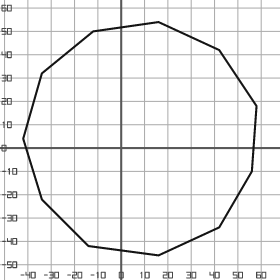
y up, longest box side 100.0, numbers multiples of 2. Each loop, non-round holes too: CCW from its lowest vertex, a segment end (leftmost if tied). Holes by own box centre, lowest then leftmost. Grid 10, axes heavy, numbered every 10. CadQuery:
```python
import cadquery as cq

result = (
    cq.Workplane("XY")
    .moveTo(16.0, -46.0)
    .lineTo(42.0, -34.0)
    .lineTo(56.0, -10.0)
    .lineTo(58.0, 18.0)
    .lineTo(42.0, 42.0)
    .lineTo(16.0, 54.0)
    .lineTo(-12.0, 50.0)
    .lineTo(-34.0, 32.0)
    .lineTo(-42.0, 4.0)
    .lineTo(-34.0, -22.0)
    .lineTo(-14.0, -42.0)
    .close()
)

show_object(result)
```